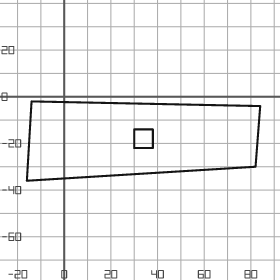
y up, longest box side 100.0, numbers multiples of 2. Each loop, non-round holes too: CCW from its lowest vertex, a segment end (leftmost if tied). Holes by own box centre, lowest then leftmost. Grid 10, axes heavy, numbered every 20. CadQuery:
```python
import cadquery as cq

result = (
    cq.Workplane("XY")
    .moveTo(-16.0, -36.0)
    .lineTo(82.0, -30.0)
    .lineTo(84.0, -4.0)
    .lineTo(-14.0, -2.0)
    .close()
    .moveTo(30.0, -22.0)
    .lineTo(38.0, -22.0)
    .lineTo(38.0, -14.0)
    .lineTo(30.0, -14.0)
    .close()
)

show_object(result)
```